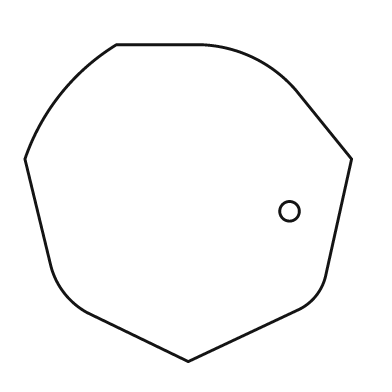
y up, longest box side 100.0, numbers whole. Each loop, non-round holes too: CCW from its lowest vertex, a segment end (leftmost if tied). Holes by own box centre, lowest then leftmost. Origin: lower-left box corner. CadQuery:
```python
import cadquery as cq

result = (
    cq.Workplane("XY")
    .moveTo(50.0, 0.0)
    .lineTo(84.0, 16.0)
    .threePointArc((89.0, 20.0), (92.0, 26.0))
    .lineTo(100.0, 62.0)
    .lineTo(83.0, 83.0)
    .threePointArc((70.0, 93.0), (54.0, 97.0))
    .lineTo(28.0, 97.0)
    .threePointArc((11.0, 82.0), (0.0, 62.0))
    .lineTo(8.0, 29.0)
    .threePointArc((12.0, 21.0), (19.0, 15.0))
    .close()
    .moveTo(81.0, 46.0)
    .circle(3.0)
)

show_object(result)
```